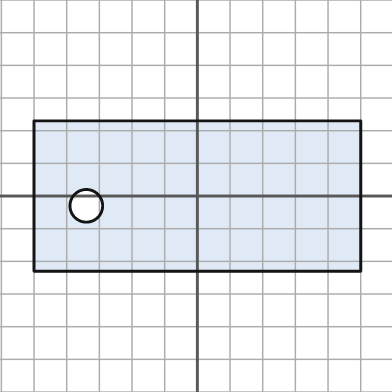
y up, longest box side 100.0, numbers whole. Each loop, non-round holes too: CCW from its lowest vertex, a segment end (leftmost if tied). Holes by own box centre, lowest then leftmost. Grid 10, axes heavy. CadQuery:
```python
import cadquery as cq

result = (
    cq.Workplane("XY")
    .moveTo(-50.0, -23.0)
    .lineTo(50.0, -23.0)
    .lineTo(50.0, 23.0)
    .lineTo(-50.0, 23.0)
    .close()
    .moveTo(-34.0, -3.0)
    .circle(5.0)
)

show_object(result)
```